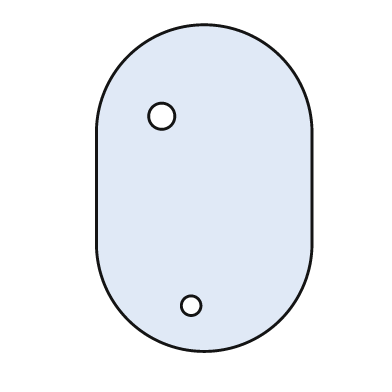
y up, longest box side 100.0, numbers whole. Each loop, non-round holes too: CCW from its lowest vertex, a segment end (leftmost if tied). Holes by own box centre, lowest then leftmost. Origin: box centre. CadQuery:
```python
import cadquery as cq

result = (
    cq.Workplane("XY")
    .moveTo(-33.0, -17.0)
    .threePointArc((0.0, -50.0), (33.0, -17.0))
    .lineTo(33.0, 17.0)
    .threePointArc((0.0, 50.0), (-33.0, 17.0))
    .close()
    .moveTo(-4.0, -36.0)
    .circle(3.0)
    .moveTo(-13.0, 22.0)
    .circle(4.0)
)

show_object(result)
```